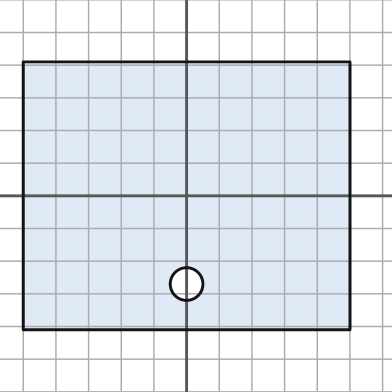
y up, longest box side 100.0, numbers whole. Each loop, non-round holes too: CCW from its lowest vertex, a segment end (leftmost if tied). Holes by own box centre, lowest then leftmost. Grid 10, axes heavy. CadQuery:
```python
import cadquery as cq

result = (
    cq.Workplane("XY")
    .moveTo(-50.0, -41.0)
    .lineTo(50.0, -41.0)
    .lineTo(50.0, 41.0)
    .lineTo(-50.0, 41.0)
    .close()
    .moveTo(0.0, -27.0)
    .circle(5.0)
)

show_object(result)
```